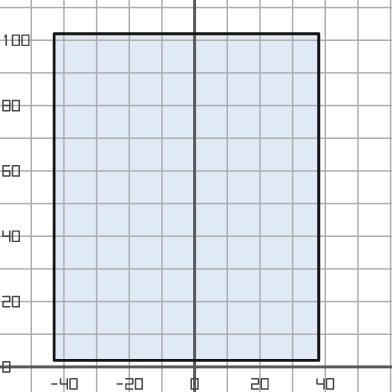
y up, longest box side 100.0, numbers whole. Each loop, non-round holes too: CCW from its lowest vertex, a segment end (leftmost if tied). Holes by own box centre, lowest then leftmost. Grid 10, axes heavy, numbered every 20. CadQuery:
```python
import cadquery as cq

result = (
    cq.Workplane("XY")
    .moveTo(-43.0, 2.0)
    .lineTo(38.0, 2.0)
    .lineTo(38.0, 102.0)
    .lineTo(-43.0, 102.0)
    .close()
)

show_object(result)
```